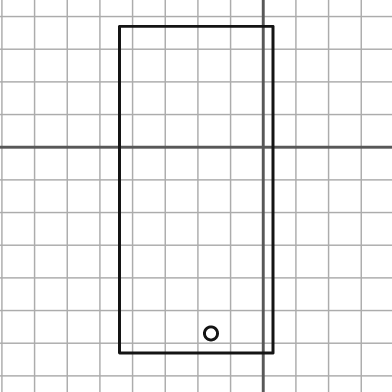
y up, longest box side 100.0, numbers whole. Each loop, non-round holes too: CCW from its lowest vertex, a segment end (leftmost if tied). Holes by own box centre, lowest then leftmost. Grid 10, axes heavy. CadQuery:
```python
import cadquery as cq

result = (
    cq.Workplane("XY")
    .moveTo(-44.0, -63.0)
    .lineTo(3.0, -63.0)
    .lineTo(3.0, 37.0)
    .lineTo(-44.0, 37.0)
    .close()
    .moveTo(-16.0, -57.0)
    .circle(2.0)
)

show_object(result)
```